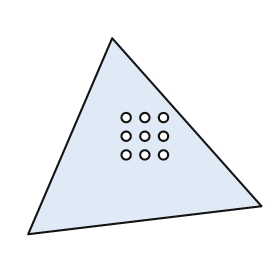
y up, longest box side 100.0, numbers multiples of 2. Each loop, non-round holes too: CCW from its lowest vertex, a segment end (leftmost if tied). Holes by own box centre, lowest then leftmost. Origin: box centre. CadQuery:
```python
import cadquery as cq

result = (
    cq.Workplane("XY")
    .moveTo(-50.0, -42.0)
    .lineTo(50.0, -30.0)
    .lineTo(-14.0, 42.0)
    .close()
    .moveTo(-8.0, -8.0)
    .circle(2.0)
    .moveTo(0.0, -8.0)
    .circle(2.0)
    .moveTo(8.0, -8.0)
    .circle(2.0)
    .moveTo(-8.0, 0.0)
    .circle(2.0)
    .moveTo(0.0, 0.0)
    .circle(2.0)
    .moveTo(8.0, 0.0)
    .circle(2.0)
    .moveTo(-8.0, 8.0)
    .circle(2.0)
    .moveTo(0.0, 8.0)
    .circle(2.0)
    .moveTo(8.0, 8.0)
    .circle(2.0)
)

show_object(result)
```